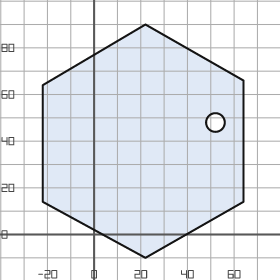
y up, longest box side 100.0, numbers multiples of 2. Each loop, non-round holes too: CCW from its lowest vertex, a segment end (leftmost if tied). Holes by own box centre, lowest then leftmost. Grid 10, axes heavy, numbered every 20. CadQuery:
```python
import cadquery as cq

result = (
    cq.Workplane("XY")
    .moveTo(22.0, -10.0)
    .lineTo(64.0, 14.0)
    .lineTo(64.0, 66.0)
    .lineTo(22.0, 90.0)
    .lineTo(-22.0, 64.0)
    .lineTo(-22.0, 14.0)
    .close()
    .moveTo(52.0, 48.0)
    .circle(4.0)
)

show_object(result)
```